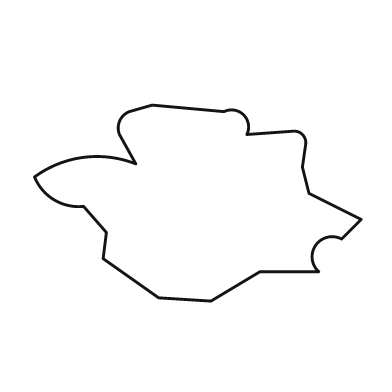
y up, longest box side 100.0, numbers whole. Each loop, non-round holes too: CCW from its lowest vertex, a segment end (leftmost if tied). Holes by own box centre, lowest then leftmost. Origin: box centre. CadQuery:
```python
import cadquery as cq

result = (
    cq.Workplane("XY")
    .moveTo(4.0, -30.0)
    .lineTo(19.0, -21.0)
    .lineTo(37.0, -21.0)
    .threePointArc((36.0, -13.0), (44.0, -11.0))
    .lineTo(50.0, -5.0)
    .lineTo(34.0, 3.0)
    .lineTo(32.0, 11.0)
    .lineTo(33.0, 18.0)
    .threePointArc((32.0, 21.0), (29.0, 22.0))
    .lineTo(15.0, 21.0)
    .threePointArc((14.0, 27.0), (8.0, 28.0))
    .lineTo(-14.0, 30.0)
    .lineTo(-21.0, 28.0)
    .threePointArc((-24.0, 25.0), (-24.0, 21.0))
    .lineTo(-19.0, 12.0)
    .threePointArc((-35.0, 14.0), (-50.0, 8.0))
    .threePointArc((-44.0, 1.0), (-35.0, -1.0))
    .lineTo(-28.0, -9.0)
    .lineTo(-29.0, -17.0)
    .lineTo(-12.0, -29.0)
    .close()
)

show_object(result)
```